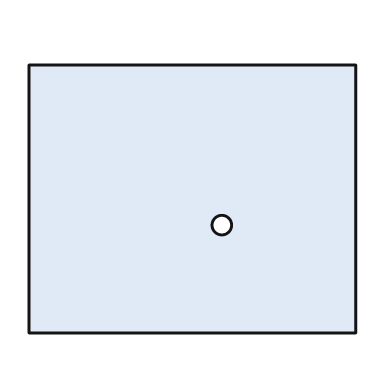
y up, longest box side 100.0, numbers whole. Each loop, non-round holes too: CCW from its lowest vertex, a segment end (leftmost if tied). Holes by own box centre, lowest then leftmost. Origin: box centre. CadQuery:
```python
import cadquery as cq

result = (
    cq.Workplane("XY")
    .moveTo(-50.0, -41.0)
    .lineTo(50.0, -41.0)
    .lineTo(50.0, 41.0)
    .lineTo(-50.0, 41.0)
    .close()
    .moveTo(9.0, -8.0)
    .circle(3.0)
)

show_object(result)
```